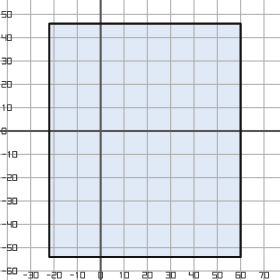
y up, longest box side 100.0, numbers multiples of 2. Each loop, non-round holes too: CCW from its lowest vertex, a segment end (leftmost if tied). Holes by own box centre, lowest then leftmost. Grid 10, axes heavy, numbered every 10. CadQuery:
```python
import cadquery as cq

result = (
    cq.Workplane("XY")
    .moveTo(-22.0, -54.0)
    .lineTo(60.0, -54.0)
    .lineTo(60.0, 46.0)
    .lineTo(-22.0, 46.0)
    .close()
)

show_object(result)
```